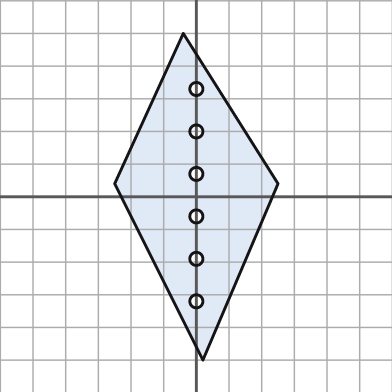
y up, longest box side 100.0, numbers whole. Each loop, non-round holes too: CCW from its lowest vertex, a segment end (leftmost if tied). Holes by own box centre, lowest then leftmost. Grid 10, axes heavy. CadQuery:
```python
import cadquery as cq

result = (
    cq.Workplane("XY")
    .moveTo(2.0, -50.0)
    .lineTo(25.0, 4.0)
    .lineTo(-4.0, 50.0)
    .lineTo(-25.0, 4.0)
    .close()
    .moveTo(0.0, -32.0)
    .circle(2.0)
    .moveTo(0.0, -19.0)
    .circle(2.0)
    .moveTo(0.0, -6.0)
    .circle(2.0)
    .moveTo(0.0, 7.0)
    .circle(2.0)
    .moveTo(0.0, 20.0)
    .circle(2.0)
    .moveTo(0.0, 33.0)
    .circle(2.0)
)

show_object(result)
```